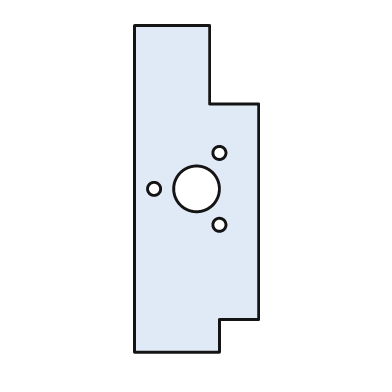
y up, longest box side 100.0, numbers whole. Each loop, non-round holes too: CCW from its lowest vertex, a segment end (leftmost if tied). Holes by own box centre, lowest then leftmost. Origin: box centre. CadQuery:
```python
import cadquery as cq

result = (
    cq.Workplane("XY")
    .moveTo(-19.0, -50.0)
    .lineTo(7.0, -50.0)
    .lineTo(7.0, -40.0)
    .lineTo(19.0, -40.0)
    .lineTo(19.0, 26.0)
    .lineTo(4.0, 26.0)
    .lineTo(4.0, 50.0)
    .lineTo(-19.0, 50.0)
    .close()
    .moveTo(7.0, -11.0)
    .circle(2.0)
    .moveTo(-13.0, 0.0)
    .circle(2.0)
    .moveTo(0.0, 0.0)
    .circle(7.0)
    .moveTo(7.0, 11.0)
    .circle(2.0)
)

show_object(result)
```